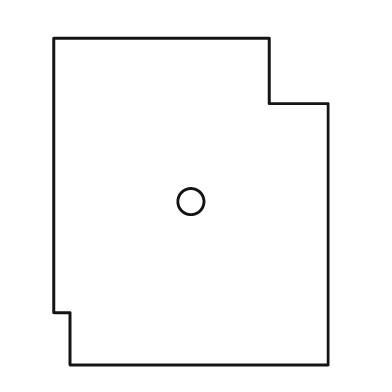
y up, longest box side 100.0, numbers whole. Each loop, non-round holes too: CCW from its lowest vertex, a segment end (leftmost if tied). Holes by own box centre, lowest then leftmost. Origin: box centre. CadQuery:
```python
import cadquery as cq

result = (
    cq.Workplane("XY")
    .moveTo(-37.0, -50.0)
    .lineTo(42.0, -50.0)
    .lineTo(42.0, 30.0)
    .lineTo(24.0, 30.0)
    .lineTo(24.0, 50.0)
    .lineTo(-42.0, 50.0)
    .lineTo(-42.0, -34.0)
    .lineTo(-37.0, -34.0)
    .close()
    .moveTo(0.0, 0.0)
    .circle(4.0)
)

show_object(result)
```